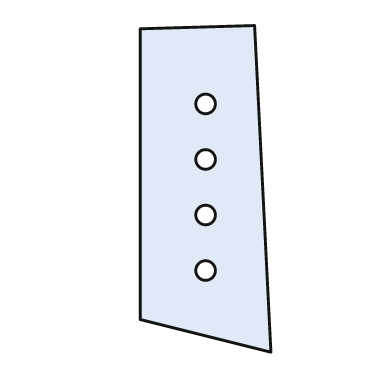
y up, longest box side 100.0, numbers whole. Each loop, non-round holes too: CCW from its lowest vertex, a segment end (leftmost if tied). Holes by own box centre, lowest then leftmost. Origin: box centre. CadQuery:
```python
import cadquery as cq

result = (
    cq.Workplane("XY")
    .moveTo(20.0, -50.0)
    .lineTo(15.0, 50.0)
    .lineTo(-20.0, 49.0)
    .lineTo(-20.0, -40.0)
    .close()
    .moveTo(0.0, -25.0)
    .circle(3.0)
    .moveTo(0.0, -8.0)
    .circle(3.0)
    .moveTo(0.0, 9.0)
    .circle(3.0)
    .moveTo(0.0, 26.0)
    .circle(3.0)
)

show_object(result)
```